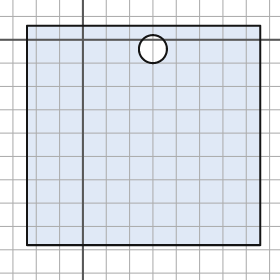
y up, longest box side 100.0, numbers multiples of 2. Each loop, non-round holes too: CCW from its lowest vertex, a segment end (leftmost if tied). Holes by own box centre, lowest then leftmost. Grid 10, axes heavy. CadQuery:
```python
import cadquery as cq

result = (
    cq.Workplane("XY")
    .moveTo(-24.0, -88.0)
    .lineTo(76.0, -88.0)
    .lineTo(76.0, 6.0)
    .lineTo(-24.0, 6.0)
    .close()
    .moveTo(30.0, -4.0)
    .circle(6.0)
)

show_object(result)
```